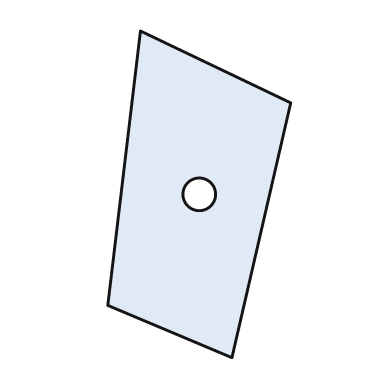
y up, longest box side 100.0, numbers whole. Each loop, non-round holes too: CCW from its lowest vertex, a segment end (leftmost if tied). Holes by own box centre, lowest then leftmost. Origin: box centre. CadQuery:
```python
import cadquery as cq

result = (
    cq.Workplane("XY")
    .moveTo(10.0, -50.0)
    .lineTo(28.0, 28.0)
    .lineTo(-18.0, 50.0)
    .lineTo(-28.0, -34.0)
    .close()
    .moveTo(0.0, 0.0)
    .circle(5.0)
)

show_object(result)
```